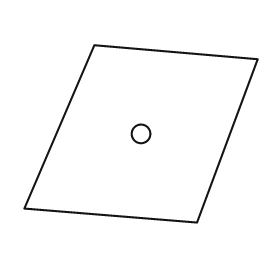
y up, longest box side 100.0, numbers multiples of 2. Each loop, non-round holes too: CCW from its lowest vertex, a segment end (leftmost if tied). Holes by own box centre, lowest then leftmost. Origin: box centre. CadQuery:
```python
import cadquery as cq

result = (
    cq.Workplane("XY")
    .moveTo(24.0, -38.0)
    .lineTo(50.0, 32.0)
    .lineTo(-20.0, 38.0)
    .lineTo(-50.0, -32.0)
    .close()
    .moveTo(0.0, 0.0)
    .circle(4.0)
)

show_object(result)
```